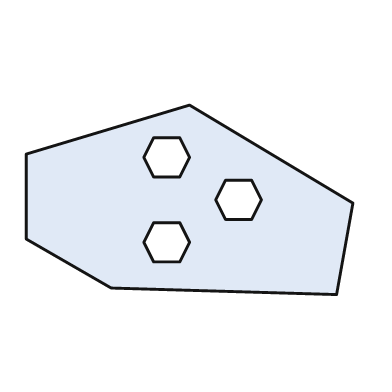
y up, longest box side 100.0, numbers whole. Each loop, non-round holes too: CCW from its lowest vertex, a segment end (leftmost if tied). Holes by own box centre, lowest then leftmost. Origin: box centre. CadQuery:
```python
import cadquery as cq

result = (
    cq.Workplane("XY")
    .moveTo(45.0, -29.0)
    .lineTo(50.0, -1.0)
    .lineTo(0.0, 29.0)
    .lineTo(-50.0, 14.0)
    .lineTo(-50.0, -12.0)
    .lineTo(-24.0, -27.0)
    .close()
    .moveTo(-11.0, -19.0)
    .lineTo(-3.0, -19.0)
    .lineTo(0.0, -13.0)
    .lineTo(-3.0, -7.0)
    .lineTo(-11.0, -7.0)
    .lineTo(-14.0, -13.0)
    .close()
    .moveTo(11.0, -6.0)
    .lineTo(19.0, -6.0)
    .lineTo(22.0, 0.0)
    .lineTo(19.0, 6.0)
    .lineTo(11.0, 6.0)
    .lineTo(8.0, 0.0)
    .close()
    .moveTo(-11.0, 7.0)
    .lineTo(-3.0, 7.0)
    .lineTo(0.0, 13.0)
    .lineTo(-3.0, 19.0)
    .lineTo(-11.0, 19.0)
    .lineTo(-14.0, 13.0)
    .close()
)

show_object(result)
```